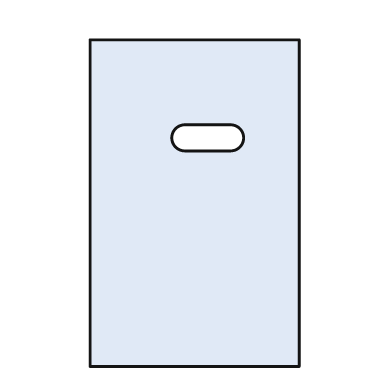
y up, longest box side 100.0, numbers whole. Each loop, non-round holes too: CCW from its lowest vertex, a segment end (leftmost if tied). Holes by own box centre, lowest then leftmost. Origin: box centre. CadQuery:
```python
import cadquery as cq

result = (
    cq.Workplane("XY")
    .moveTo(-32.0, -50.0)
    .lineTo(32.0, -50.0)
    .lineTo(32.0, 50.0)
    .lineTo(-32.0, 50.0)
    .close()
    .moveTo(-3.0, 16.0)
    .lineTo(11.0, 16.0)
    .threePointArc((15.0, 20.0), (11.0, 24.0))
    .lineTo(-3.0, 24.0)
    .threePointArc((-7.0, 20.0), (-3.0, 16.0))
    .close()
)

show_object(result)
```